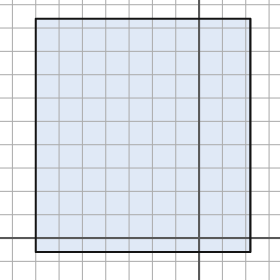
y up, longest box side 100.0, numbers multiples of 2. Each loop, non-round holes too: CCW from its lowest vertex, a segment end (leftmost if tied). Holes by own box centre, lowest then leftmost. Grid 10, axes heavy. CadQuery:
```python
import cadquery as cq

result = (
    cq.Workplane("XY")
    .moveTo(-70.0, -6.0)
    .lineTo(22.0, -6.0)
    .lineTo(22.0, 94.0)
    .lineTo(-70.0, 94.0)
    .close()
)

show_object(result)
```